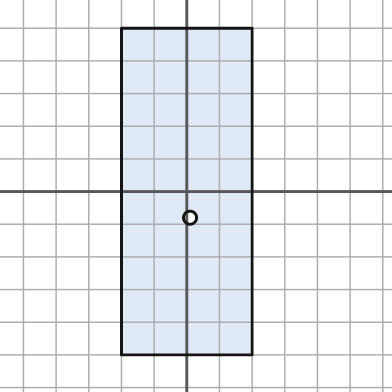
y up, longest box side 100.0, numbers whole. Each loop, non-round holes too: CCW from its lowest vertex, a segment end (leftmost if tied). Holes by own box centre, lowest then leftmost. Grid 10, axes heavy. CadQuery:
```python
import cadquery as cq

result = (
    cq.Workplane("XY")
    .moveTo(-20.0, -50.0)
    .lineTo(20.0, -50.0)
    .lineTo(20.0, 50.0)
    .lineTo(-20.0, 50.0)
    .close()
    .moveTo(1.0, -8.0)
    .circle(2.0)
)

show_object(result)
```